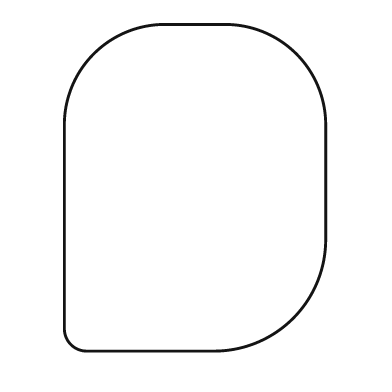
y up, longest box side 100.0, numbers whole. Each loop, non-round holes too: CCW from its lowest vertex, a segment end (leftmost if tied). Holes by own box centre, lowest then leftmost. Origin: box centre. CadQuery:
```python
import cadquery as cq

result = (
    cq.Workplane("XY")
    .moveTo(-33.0, -50.0)
    .lineTo(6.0, -50.0)
    .threePointArc((30.0, -40.0), (40.0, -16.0))
    .lineTo(40.0, 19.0)
    .threePointArc((31.0, 41.0), (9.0, 50.0))
    .lineTo(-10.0, 50.0)
    .threePointArc((-31.0, 41.0), (-40.0, 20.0))
    .lineTo(-40.0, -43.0)
    .threePointArc((-38.0, -48.0), (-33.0, -50.0))
    .close()
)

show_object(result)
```